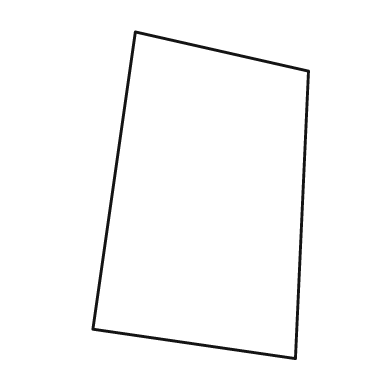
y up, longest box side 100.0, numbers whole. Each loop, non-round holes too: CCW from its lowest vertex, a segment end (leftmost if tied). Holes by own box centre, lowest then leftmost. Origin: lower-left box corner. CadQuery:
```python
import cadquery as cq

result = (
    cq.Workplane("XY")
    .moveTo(62.0, 0.0)
    .lineTo(66.0, 88.0)
    .lineTo(13.0, 100.0)
    .lineTo(0.0, 9.0)
    .close()
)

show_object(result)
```